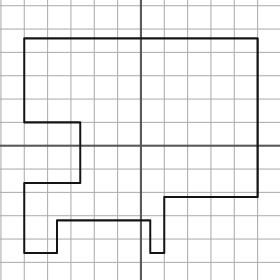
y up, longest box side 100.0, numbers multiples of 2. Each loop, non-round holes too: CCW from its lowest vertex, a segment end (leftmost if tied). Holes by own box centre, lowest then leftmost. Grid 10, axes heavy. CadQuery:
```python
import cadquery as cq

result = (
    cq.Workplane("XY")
    .moveTo(-50.0, -46.0)
    .lineTo(-36.0, -46.0)
    .lineTo(-36.0, -32.0)
    .lineTo(4.0, -32.0)
    .lineTo(4.0, -46.0)
    .lineTo(10.0, -46.0)
    .lineTo(10.0, -22.0)
    .lineTo(50.0, -22.0)
    .lineTo(50.0, 46.0)
    .lineTo(-50.0, 46.0)
    .lineTo(-50.0, 10.0)
    .lineTo(-26.0, 10.0)
    .lineTo(-26.0, -16.0)
    .lineTo(-50.0, -16.0)
    .close()
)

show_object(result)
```